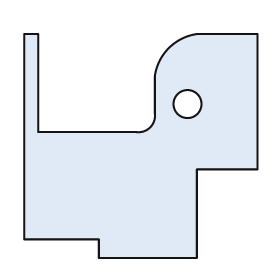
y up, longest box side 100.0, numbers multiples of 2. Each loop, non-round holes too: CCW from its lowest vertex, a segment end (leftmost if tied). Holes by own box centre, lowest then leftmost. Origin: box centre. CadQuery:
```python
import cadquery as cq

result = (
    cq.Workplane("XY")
    .moveTo(-18.0, -48.0)
    .lineTo(24.0, -48.0)
    .lineTo(24.0, -10.0)
    .lineTo(50.0, -10.0)
    .lineTo(50.0, 48.0)
    .lineTo(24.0, 48.0)
    .threePointArc((12.0, 42.0), (6.0, 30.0))
    .lineTo(6.0, 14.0)
    .threePointArc((4.0, 8.0), (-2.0, 6.0))
    .lineTo(-44.0, 6.0)
    .lineTo(-44.0, 48.0)
    .lineTo(-50.0, 48.0)
    .lineTo(-50.0, -40.0)
    .lineTo(-18.0, -40.0)
    .close()
    .moveTo(20.0, 18.0)
    .circle(6.0)
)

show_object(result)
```